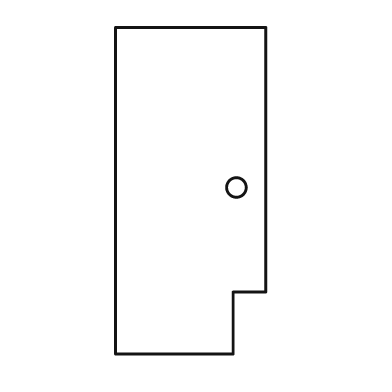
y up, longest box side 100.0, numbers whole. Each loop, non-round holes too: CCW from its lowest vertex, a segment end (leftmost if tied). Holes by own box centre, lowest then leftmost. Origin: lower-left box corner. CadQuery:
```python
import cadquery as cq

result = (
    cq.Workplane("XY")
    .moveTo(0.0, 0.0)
    .lineTo(36.0, 0.0)
    .lineTo(36.0, 19.0)
    .lineTo(46.0, 19.0)
    .lineTo(46.0, 100.0)
    .lineTo(0.0, 100.0)
    .close()
    .moveTo(37.0, 51.0)
    .circle(3.0)
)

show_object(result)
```